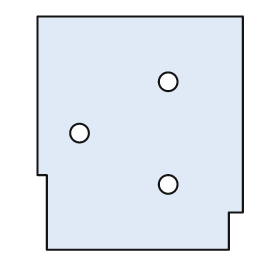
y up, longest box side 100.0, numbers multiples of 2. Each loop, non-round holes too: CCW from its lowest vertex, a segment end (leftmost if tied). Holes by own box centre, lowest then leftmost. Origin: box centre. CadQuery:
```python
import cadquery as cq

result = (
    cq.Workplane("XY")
    .moveTo(-40.0, -50.0)
    .lineTo(38.0, -50.0)
    .lineTo(38.0, -34.0)
    .lineTo(44.0, -34.0)
    .lineTo(44.0, 50.0)
    .lineTo(-44.0, 50.0)
    .lineTo(-44.0, -18.0)
    .lineTo(-40.0, -18.0)
    .close()
    .moveTo(12.0, -22.0)
    .circle(4.0)
    .moveTo(-26.0, 0.0)
    .circle(4.0)
    .moveTo(12.0, 22.0)
    .circle(4.0)
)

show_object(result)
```